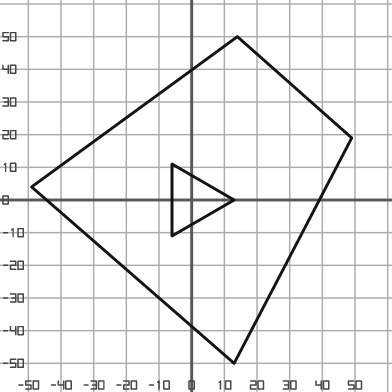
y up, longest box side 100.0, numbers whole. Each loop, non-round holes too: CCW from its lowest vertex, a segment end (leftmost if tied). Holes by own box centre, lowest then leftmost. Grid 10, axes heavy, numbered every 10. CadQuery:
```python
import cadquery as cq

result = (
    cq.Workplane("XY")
    .moveTo(13.0, -50.0)
    .lineTo(49.0, 19.0)
    .lineTo(14.0, 50.0)
    .lineTo(-49.0, 4.0)
    .close()
    .moveTo(-6.0, -11.0)
    .lineTo(13.0, 0.0)
    .lineTo(-6.0, 11.0)
    .close()
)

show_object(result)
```